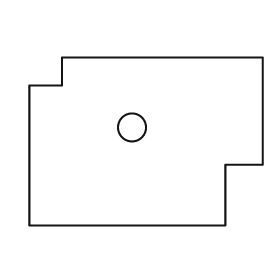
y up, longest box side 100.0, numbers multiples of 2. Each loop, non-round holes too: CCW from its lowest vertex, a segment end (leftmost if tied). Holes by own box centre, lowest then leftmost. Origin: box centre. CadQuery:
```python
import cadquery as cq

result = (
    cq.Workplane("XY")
    .moveTo(-50.0, -36.0)
    .lineTo(34.0, -36.0)
    .lineTo(34.0, -10.0)
    .lineTo(50.0, -10.0)
    .lineTo(50.0, 36.0)
    .lineTo(-36.0, 36.0)
    .lineTo(-36.0, 24.0)
    .lineTo(-50.0, 24.0)
    .close()
    .moveTo(-6.0, 6.0)
    .circle(6.0)
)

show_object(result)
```